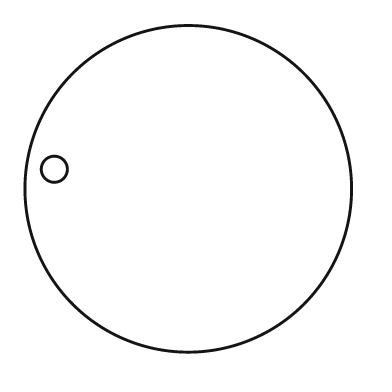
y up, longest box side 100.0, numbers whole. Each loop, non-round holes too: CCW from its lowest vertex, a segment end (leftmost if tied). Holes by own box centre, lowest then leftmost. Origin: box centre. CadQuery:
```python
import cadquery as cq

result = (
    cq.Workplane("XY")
    .moveTo(0.0, 0.0)
    .circle(50.0)
    .moveTo(-41.0, 6.0)
    .circle(4.0)
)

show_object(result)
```